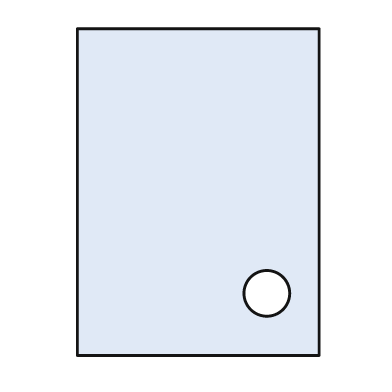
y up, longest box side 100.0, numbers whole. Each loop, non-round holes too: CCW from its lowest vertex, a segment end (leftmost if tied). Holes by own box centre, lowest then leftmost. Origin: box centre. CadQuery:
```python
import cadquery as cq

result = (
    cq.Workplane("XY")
    .moveTo(-37.0, -50.0)
    .lineTo(37.0, -50.0)
    .lineTo(37.0, 50.0)
    .lineTo(-37.0, 50.0)
    .close()
    .moveTo(21.0, -31.0)
    .circle(7.0)
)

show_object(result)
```